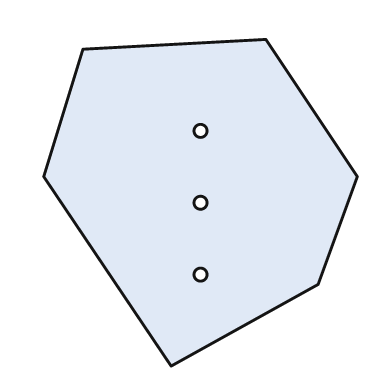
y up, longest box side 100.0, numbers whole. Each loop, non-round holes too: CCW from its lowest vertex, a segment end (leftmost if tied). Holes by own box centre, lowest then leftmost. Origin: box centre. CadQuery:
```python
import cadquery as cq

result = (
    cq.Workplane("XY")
    .moveTo(-9.0, -50.0)
    .lineTo(36.0, -25.0)
    .lineTo(48.0, 8.0)
    .lineTo(20.0, 50.0)
    .lineTo(-36.0, 47.0)
    .lineTo(-48.0, 8.0)
    .close()
    .moveTo(0.0, -22.0)
    .circle(2.0)
    .moveTo(0.0, 0.0)
    .circle(2.0)
    .moveTo(0.0, 22.0)
    .circle(2.0)
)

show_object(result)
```